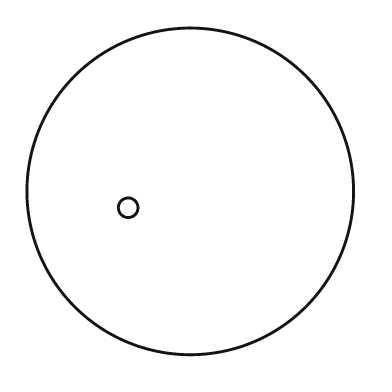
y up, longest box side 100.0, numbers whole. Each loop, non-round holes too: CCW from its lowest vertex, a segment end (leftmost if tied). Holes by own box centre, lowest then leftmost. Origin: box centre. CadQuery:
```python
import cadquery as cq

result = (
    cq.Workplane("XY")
    .moveTo(0.0, 0.0)
    .circle(50.0)
    .moveTo(-19.0, -5.0)
    .circle(3.0)
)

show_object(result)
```